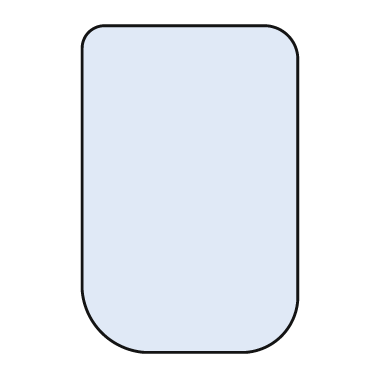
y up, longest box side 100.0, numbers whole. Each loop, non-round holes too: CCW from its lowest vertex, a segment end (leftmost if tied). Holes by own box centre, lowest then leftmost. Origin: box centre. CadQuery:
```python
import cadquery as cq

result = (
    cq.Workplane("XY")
    .moveTo(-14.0, -50.0)
    .lineTo(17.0, -50.0)
    .threePointArc((28.0, -45.0), (33.0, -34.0))
    .lineTo(33.0, 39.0)
    .threePointArc((30.0, 47.0), (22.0, 50.0))
    .lineTo(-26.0, 50.0)
    .threePointArc((-31.0, 48.0), (-33.0, 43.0))
    .lineTo(-33.0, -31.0)
    .threePointArc((-27.0, -44.0), (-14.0, -50.0))
    .close()
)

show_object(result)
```